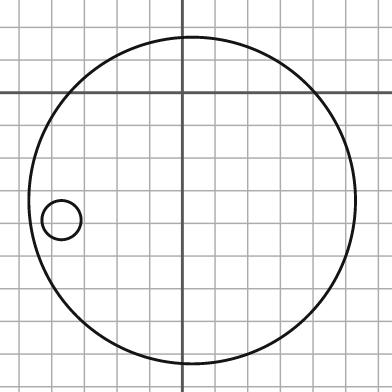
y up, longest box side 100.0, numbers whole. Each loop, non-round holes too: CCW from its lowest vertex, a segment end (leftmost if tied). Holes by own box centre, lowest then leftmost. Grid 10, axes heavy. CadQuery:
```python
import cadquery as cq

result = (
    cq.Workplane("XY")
    .moveTo(3.0, -33.0)
    .circle(50.0)
    .moveTo(-37.0, -39.0)
    .circle(6.0)
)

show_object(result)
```